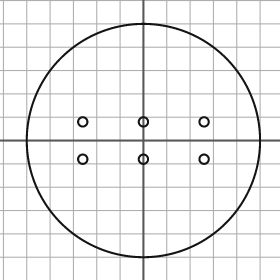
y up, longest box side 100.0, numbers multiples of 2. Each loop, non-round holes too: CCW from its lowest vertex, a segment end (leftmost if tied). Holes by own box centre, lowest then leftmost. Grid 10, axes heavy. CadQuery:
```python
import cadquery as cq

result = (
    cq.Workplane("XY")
    .moveTo(0.0, 0.0)
    .circle(50.0)
    .moveTo(-26.0, -8.0)
    .circle(2.0)
    .moveTo(0.0, -8.0)
    .circle(2.0)
    .moveTo(26.0, -8.0)
    .circle(2.0)
    .moveTo(-26.0, 8.0)
    .circle(2.0)
    .moveTo(0.0, 8.0)
    .circle(2.0)
    .moveTo(26.0, 8.0)
    .circle(2.0)
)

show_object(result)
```